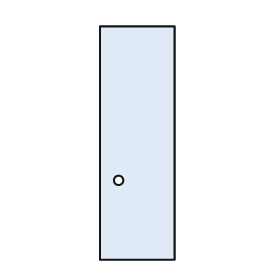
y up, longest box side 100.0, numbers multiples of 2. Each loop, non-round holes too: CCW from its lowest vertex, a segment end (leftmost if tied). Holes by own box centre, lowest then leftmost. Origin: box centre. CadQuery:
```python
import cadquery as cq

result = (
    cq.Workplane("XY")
    .moveTo(-16.0, -50.0)
    .lineTo(16.0, -50.0)
    .lineTo(16.0, 50.0)
    .lineTo(-16.0, 50.0)
    .close()
    .moveTo(-8.0, -16.0)
    .circle(2.0)
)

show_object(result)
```